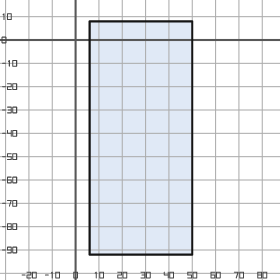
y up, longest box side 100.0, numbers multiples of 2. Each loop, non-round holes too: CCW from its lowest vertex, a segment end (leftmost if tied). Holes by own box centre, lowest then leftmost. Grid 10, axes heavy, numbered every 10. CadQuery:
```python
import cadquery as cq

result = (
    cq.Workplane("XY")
    .moveTo(6.0, -92.0)
    .lineTo(50.0, -92.0)
    .lineTo(50.0, 8.0)
    .lineTo(6.0, 8.0)
    .close()
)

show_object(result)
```